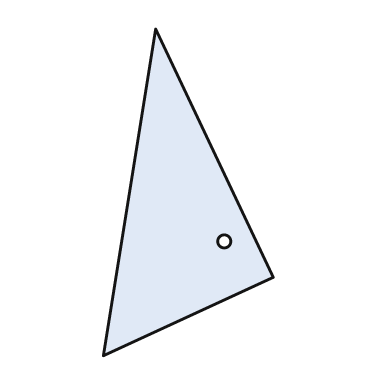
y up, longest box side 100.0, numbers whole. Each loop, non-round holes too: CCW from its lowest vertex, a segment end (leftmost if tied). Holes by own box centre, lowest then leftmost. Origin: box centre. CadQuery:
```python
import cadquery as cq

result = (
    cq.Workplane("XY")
    .moveTo(-26.0, -50.0)
    .lineTo(26.0, -26.0)
    .lineTo(-10.0, 50.0)
    .close()
    .moveTo(11.0, -15.0)
    .circle(2.0)
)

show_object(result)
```